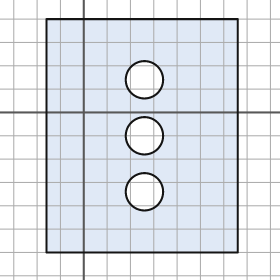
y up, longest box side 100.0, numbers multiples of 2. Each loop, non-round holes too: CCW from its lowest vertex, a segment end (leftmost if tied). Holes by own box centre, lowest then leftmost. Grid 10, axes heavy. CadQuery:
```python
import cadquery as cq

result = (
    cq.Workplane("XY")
    .moveTo(-16.0, -60.0)
    .lineTo(66.0, -60.0)
    .lineTo(66.0, 40.0)
    .lineTo(-16.0, 40.0)
    .close()
    .moveTo(26.0, -34.0)
    .circle(8.0)
    .moveTo(26.0, -10.0)
    .circle(8.0)
    .moveTo(26.0, 14.0)
    .circle(8.0)
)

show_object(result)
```